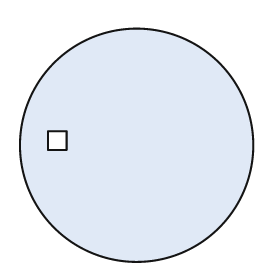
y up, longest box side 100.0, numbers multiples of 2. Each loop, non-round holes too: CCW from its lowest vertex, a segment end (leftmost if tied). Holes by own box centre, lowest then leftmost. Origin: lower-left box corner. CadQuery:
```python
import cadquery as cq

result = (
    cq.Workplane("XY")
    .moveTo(50.0, 50.0)
    .circle(50.0)
    .moveTo(12.0, 48.0)
    .lineTo(20.0, 48.0)
    .lineTo(20.0, 56.0)
    .lineTo(12.0, 56.0)
    .close()
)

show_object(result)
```